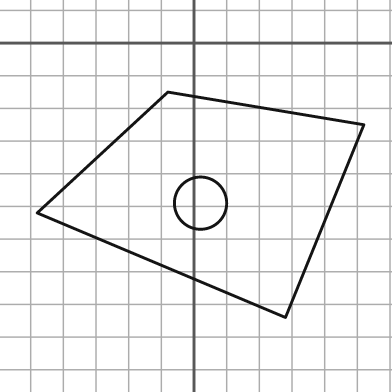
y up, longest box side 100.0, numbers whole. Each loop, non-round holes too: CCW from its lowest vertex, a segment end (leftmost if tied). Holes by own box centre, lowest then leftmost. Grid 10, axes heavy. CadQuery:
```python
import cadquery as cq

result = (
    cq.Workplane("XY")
    .moveTo(28.0, -84.0)
    .lineTo(52.0, -25.0)
    .lineTo(-8.0, -15.0)
    .lineTo(-48.0, -52.0)
    .close()
    .moveTo(2.0, -49.0)
    .circle(8.0)
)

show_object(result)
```